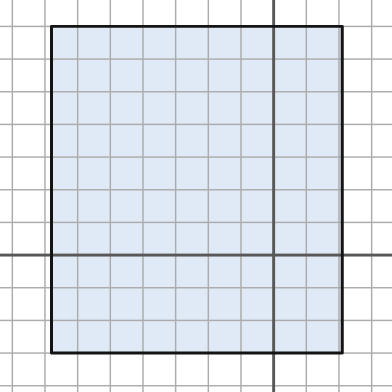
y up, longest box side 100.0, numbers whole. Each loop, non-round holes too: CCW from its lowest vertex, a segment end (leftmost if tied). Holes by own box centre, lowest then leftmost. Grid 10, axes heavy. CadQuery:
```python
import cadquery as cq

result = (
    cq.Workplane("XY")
    .moveTo(-68.0, -30.0)
    .lineTo(21.0, -30.0)
    .lineTo(21.0, 70.0)
    .lineTo(-68.0, 70.0)
    .close()
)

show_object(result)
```